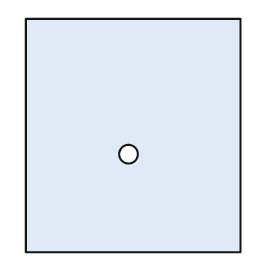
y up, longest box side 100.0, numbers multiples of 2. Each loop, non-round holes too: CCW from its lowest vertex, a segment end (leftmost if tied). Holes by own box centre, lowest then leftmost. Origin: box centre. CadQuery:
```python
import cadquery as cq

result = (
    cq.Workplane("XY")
    .moveTo(-46.0, -50.0)
    .lineTo(46.0, -50.0)
    .lineTo(46.0, 50.0)
    .lineTo(-46.0, 50.0)
    .close()
    .moveTo(-2.0, -8.0)
    .circle(4.0)
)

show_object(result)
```